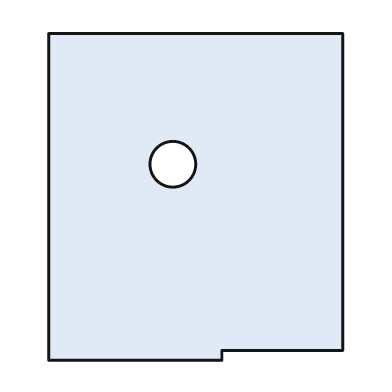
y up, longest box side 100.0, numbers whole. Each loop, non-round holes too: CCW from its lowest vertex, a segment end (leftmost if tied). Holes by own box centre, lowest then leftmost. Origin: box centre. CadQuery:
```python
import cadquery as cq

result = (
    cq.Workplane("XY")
    .moveTo(-45.0, -50.0)
    .lineTo(8.0, -50.0)
    .lineTo(8.0, -47.0)
    .lineTo(45.0, -47.0)
    .lineTo(45.0, 50.0)
    .lineTo(-45.0, 50.0)
    .close()
    .moveTo(-7.0, 10.0)
    .circle(7.0)
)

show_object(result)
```